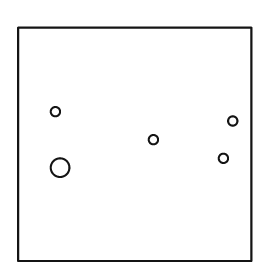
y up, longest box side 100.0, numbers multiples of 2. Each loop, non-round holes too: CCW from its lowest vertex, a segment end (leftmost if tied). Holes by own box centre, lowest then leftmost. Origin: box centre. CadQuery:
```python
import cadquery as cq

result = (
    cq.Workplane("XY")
    .moveTo(-50.0, -50.0)
    .lineTo(50.0, -50.0)
    .lineTo(50.0, 50.0)
    .lineTo(-50.0, 50.0)
    .close()
    .moveTo(-32.0, -10.0)
    .circle(4.0)
    .moveTo(38.0, -6.0)
    .circle(2.0)
    .moveTo(8.0, 2.0)
    .circle(2.0)
    .moveTo(42.0, 10.0)
    .circle(2.0)
    .moveTo(-34.0, 14.0)
    .circle(2.0)
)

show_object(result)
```